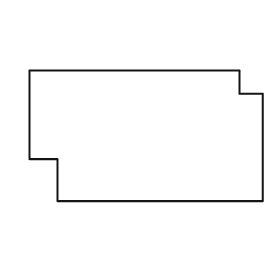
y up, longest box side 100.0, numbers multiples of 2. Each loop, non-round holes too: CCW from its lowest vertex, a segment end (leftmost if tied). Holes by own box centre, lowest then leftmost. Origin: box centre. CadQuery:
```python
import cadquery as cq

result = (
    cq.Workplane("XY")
    .moveTo(-38.0, -28.0)
    .lineTo(50.0, -28.0)
    .lineTo(50.0, 18.0)
    .lineTo(40.0, 18.0)
    .lineTo(40.0, 28.0)
    .lineTo(-50.0, 28.0)
    .lineTo(-50.0, -10.0)
    .lineTo(-38.0, -10.0)
    .close()
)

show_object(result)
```